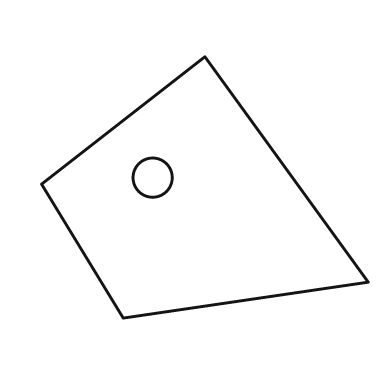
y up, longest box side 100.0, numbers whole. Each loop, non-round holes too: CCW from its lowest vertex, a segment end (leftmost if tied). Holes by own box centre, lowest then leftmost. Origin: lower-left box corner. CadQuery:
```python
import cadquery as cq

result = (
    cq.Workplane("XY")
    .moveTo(25.0, 0.0)
    .lineTo(100.0, 11.0)
    .lineTo(50.0, 80.0)
    .lineTo(0.0, 41.0)
    .close()
    .moveTo(34.0, 43.0)
    .circle(6.0)
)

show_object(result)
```